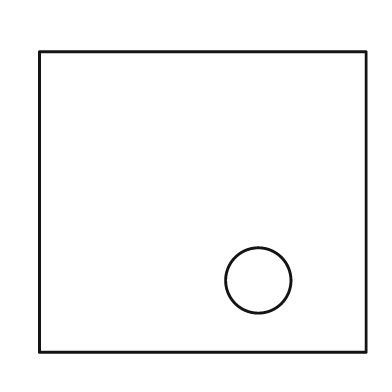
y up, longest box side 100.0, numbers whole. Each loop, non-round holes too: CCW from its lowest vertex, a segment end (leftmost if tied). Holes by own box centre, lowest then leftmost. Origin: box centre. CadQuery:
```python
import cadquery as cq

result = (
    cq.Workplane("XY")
    .moveTo(-50.0, -46.0)
    .lineTo(50.0, -46.0)
    .lineTo(50.0, 46.0)
    .lineTo(-50.0, 46.0)
    .close()
    .moveTo(17.0, -24.0)
    .circle(10.0)
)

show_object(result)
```